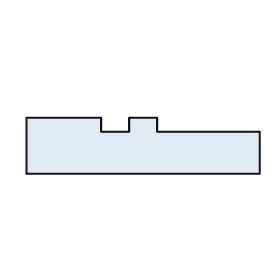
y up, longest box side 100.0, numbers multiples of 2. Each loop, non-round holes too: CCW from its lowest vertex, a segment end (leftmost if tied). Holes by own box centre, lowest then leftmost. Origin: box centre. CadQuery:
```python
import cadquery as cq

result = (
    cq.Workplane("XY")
    .moveTo(-50.0, -12.0)
    .lineTo(50.0, -12.0)
    .lineTo(50.0, 6.0)
    .lineTo(6.0, 6.0)
    .lineTo(6.0, 12.0)
    .lineTo(-6.0, 12.0)
    .lineTo(-6.0, 6.0)
    .lineTo(-18.0, 6.0)
    .lineTo(-18.0, 12.0)
    .lineTo(-50.0, 12.0)
    .close()
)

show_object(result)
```